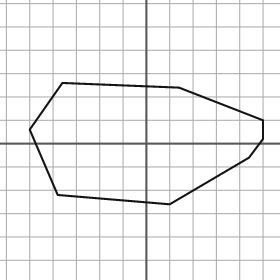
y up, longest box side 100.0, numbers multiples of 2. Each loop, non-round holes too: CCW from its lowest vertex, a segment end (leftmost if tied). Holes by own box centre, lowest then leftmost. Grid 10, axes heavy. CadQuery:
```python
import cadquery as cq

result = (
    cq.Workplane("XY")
    .moveTo(10.0, -26.0)
    .lineTo(44.0, -6.0)
    .lineTo(50.0, 2.0)
    .lineTo(50.0, 10.0)
    .lineTo(14.0, 24.0)
    .lineTo(-36.0, 26.0)
    .lineTo(-50.0, 6.0)
    .lineTo(-38.0, -22.0)
    .close()
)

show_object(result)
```